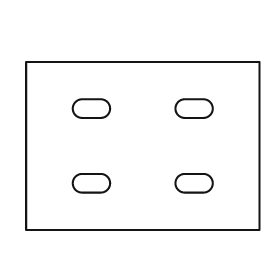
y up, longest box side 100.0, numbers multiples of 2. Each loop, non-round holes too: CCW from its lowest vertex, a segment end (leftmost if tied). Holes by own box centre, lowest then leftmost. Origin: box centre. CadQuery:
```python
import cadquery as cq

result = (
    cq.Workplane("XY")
    .moveTo(-50.0, -36.0)
    .lineTo(50.0, -36.0)
    .lineTo(50.0, 36.0)
    .lineTo(-50.0, 36.0)
    .close()
    .moveTo(-26.0, -20.0)
    .lineTo(-18.0, -20.0)
    .threePointArc((-14.0, -16.0), (-18.0, -12.0))
    .lineTo(-26.0, -12.0)
    .threePointArc((-30.0, -16.0), (-26.0, -20.0))
    .close()
    .moveTo(18.0, -20.0)
    .lineTo(26.0, -20.0)
    .threePointArc((30.0, -16.0), (26.0, -12.0))
    .lineTo(18.0, -12.0)
    .threePointArc((14.0, -16.0), (18.0, -20.0))
    .close()
    .moveTo(-26.0, 12.0)
    .lineTo(-18.0, 12.0)
    .threePointArc((-14.0, 16.0), (-18.0, 20.0))
    .lineTo(-26.0, 20.0)
    .threePointArc((-30.0, 16.0), (-26.0, 12.0))
    .close()
    .moveTo(18.0, 12.0)
    .lineTo(26.0, 12.0)
    .threePointArc((30.0, 16.0), (26.0, 20.0))
    .lineTo(18.0, 20.0)
    .threePointArc((14.0, 16.0), (18.0, 12.0))
    .close()
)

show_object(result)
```